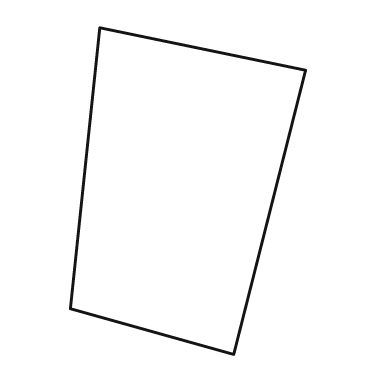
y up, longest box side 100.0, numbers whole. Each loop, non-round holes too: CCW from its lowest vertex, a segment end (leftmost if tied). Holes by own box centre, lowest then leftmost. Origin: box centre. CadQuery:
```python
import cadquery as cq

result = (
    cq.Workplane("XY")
    .moveTo(14.0, -50.0)
    .lineTo(36.0, 37.0)
    .lineTo(-27.0, 50.0)
    .lineTo(-36.0, -36.0)
    .close()
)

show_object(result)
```